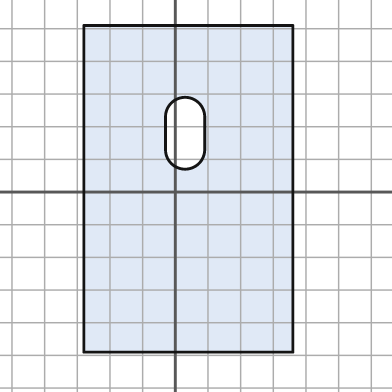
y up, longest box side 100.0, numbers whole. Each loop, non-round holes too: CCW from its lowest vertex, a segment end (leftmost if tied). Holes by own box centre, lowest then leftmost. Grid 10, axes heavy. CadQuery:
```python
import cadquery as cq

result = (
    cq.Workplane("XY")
    .moveTo(-28.0, -49.0)
    .lineTo(36.0, -49.0)
    .lineTo(36.0, 51.0)
    .lineTo(-28.0, 51.0)
    .close()
    .moveTo(-3.0, 13.0)
    .threePointArc((3.0, 7.0), (9.0, 13.0))
    .lineTo(9.0, 23.0)
    .threePointArc((3.0, 29.0), (-3.0, 23.0))
    .close()
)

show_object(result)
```